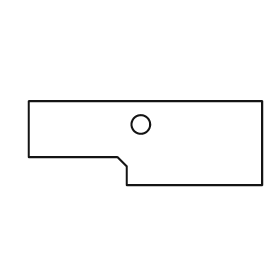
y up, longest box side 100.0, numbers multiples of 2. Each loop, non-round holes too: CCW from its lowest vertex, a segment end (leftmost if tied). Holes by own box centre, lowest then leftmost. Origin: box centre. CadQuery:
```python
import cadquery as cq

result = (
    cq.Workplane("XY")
    .moveTo(-8.0, -18.0)
    .lineTo(50.0, -18.0)
    .lineTo(50.0, 18.0)
    .lineTo(-50.0, 18.0)
    .lineTo(-50.0, -6.0)
    .lineTo(-12.0, -6.0)
    .lineTo(-8.0, -10.0)
    .close()
    .moveTo(-2.0, 8.0)
    .circle(4.0)
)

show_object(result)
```